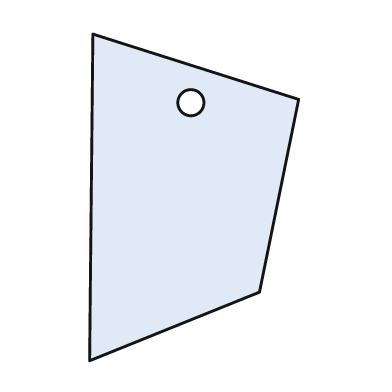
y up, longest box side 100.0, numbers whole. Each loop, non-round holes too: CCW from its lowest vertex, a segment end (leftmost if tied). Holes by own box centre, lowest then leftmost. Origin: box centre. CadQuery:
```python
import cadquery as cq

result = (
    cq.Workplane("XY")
    .moveTo(-32.0, -50.0)
    .lineTo(20.0, -29.0)
    .lineTo(32.0, 30.0)
    .lineTo(-31.0, 50.0)
    .close()
    .moveTo(-1.0, 29.0)
    .circle(4.0)
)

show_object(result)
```